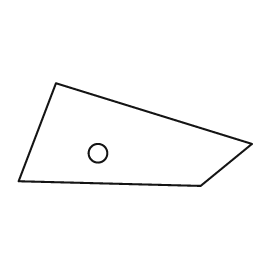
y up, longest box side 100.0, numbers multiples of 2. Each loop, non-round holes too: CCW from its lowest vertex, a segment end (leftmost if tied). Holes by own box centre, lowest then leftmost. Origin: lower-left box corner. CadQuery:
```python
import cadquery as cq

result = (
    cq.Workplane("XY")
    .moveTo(78.0, 0.0)
    .lineTo(100.0, 18.0)
    .lineTo(16.0, 44.0)
    .lineTo(0.0, 2.0)
    .close()
    .moveTo(34.0, 14.0)
    .circle(4.0)
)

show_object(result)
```